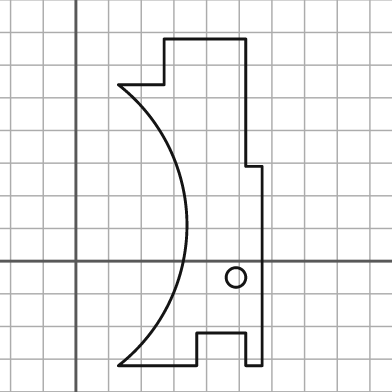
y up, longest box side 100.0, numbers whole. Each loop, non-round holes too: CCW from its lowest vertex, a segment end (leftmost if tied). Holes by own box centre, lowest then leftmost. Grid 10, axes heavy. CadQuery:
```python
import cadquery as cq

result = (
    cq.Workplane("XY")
    .moveTo(13.0, -32.0)
    .lineTo(37.0, -32.0)
    .lineTo(37.0, -22.0)
    .lineTo(52.0, -22.0)
    .lineTo(52.0, -32.0)
    .lineTo(57.0, -32.0)
    .lineTo(57.0, 29.0)
    .lineTo(52.0, 29.0)
    .lineTo(52.0, 68.0)
    .lineTo(27.0, 68.0)
    .lineTo(27.0, 54.0)
    .lineTo(13.0, 54.0)
    .threePointArc((34.0, 11.0), (13.0, -32.0))
    .close()
    .moveTo(49.0, -5.0)
    .circle(3.0)
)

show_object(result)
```